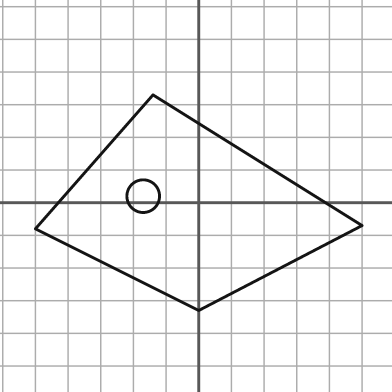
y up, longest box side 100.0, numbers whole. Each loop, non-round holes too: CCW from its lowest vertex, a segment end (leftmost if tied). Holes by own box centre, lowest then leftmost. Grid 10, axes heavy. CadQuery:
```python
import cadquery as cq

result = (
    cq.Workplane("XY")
    .moveTo(0.0, -33.0)
    .lineTo(50.0, -7.0)
    .lineTo(-14.0, 33.0)
    .lineTo(-50.0, -8.0)
    .close()
    .moveTo(-17.0, 2.0)
    .circle(5.0)
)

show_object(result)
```